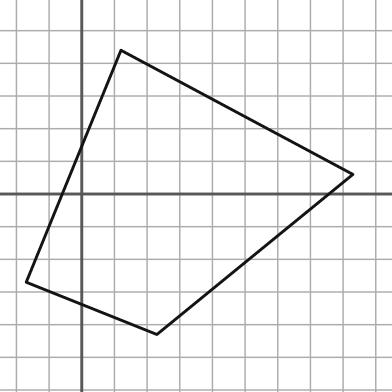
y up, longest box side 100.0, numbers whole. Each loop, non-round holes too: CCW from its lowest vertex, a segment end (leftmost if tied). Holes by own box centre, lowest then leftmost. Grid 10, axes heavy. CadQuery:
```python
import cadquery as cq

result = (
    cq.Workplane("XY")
    .moveTo(23.0, -43.0)
    .lineTo(83.0, 6.0)
    .lineTo(12.0, 44.0)
    .lineTo(-17.0, -27.0)
    .close()
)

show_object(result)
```